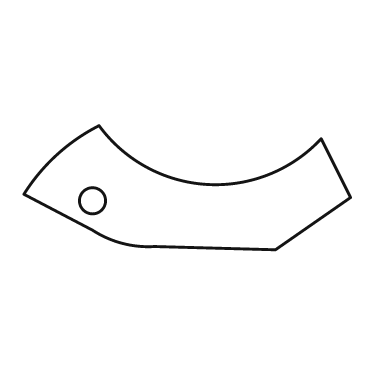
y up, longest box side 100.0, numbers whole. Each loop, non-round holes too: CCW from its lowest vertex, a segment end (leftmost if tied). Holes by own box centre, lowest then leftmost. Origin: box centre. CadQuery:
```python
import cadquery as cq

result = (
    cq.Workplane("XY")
    .moveTo(27.0, -19.0)
    .lineTo(50.0, -3.0)
    .lineTo(41.0, 15.0)
    .threePointArc((6.0, 1.0), (-27.0, 19.0))
    .threePointArc((-40.0, 10.0), (-50.0, -2.0))
    .lineTo(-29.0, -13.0)
    .threePointArc((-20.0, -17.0), (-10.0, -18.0))
    .close()
    .moveTo(-29.0, -4.0)
    .circle(4.0)
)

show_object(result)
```